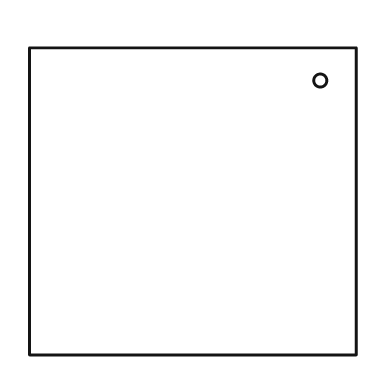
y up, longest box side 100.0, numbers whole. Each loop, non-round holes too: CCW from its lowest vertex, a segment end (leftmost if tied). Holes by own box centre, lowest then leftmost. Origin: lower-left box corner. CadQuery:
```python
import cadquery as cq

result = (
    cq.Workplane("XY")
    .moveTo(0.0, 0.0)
    .lineTo(100.0, 0.0)
    .lineTo(100.0, 94.0)
    .lineTo(0.0, 94.0)
    .close()
    .moveTo(89.0, 84.0)
    .circle(2.0)
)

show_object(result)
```